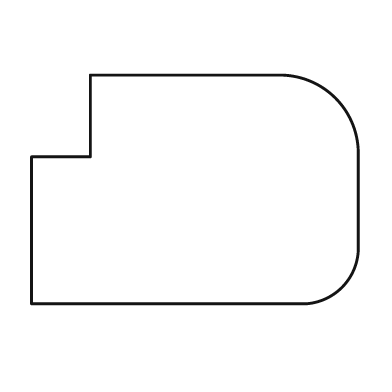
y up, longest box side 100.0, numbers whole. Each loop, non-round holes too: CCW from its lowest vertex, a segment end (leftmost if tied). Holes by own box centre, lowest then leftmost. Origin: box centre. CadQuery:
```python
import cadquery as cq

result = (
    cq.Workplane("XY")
    .moveTo(-50.0, -35.0)
    .lineTo(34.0, -35.0)
    .threePointArc((45.0, -30.0), (50.0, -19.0))
    .lineTo(50.0, 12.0)
    .threePointArc((43.0, 28.0), (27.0, 35.0))
    .lineTo(-32.0, 35.0)
    .lineTo(-32.0, 10.0)
    .lineTo(-50.0, 10.0)
    .close()
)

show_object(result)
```